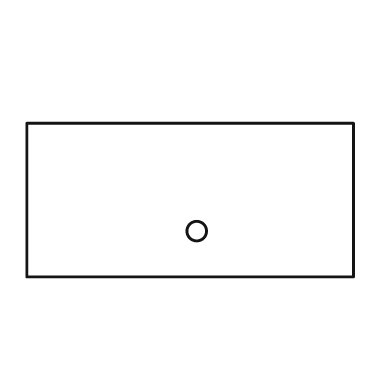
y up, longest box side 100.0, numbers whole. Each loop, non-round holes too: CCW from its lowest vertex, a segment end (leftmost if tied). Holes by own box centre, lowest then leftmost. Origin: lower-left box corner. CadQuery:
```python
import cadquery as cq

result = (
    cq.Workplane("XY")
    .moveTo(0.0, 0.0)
    .lineTo(100.0, 0.0)
    .lineTo(100.0, 47.0)
    .lineTo(0.0, 47.0)
    .close()
    .moveTo(52.0, 14.0)
    .circle(3.0)
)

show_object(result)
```